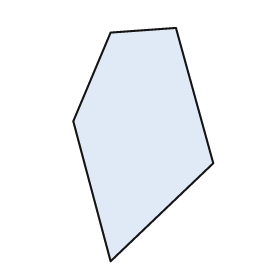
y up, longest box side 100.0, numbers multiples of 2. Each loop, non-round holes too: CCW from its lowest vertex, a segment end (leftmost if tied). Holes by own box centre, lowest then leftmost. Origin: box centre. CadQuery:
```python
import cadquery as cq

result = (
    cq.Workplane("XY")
    .moveTo(-14.0, -50.0)
    .lineTo(30.0, -8.0)
    .lineTo(14.0, 50.0)
    .lineTo(-14.0, 48.0)
    .lineTo(-30.0, 10.0)
    .close()
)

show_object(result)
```